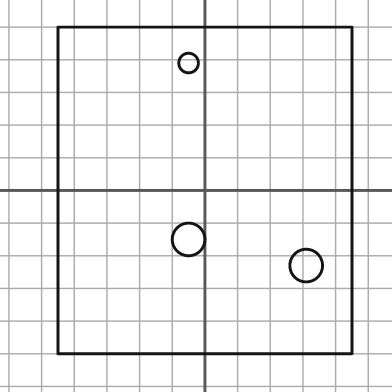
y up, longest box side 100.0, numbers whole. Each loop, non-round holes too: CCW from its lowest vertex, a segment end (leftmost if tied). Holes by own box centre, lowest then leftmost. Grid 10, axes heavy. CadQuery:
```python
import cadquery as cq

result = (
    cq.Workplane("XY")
    .moveTo(-45.0, -50.0)
    .lineTo(45.0, -50.0)
    .lineTo(45.0, 50.0)
    .lineTo(-45.0, 50.0)
    .close()
    .moveTo(31.0, -23.0)
    .circle(5.0)
    .moveTo(-5.0, -15.0)
    .circle(5.0)
    .moveTo(-5.0, 39.0)
    .circle(3.0)
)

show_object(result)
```